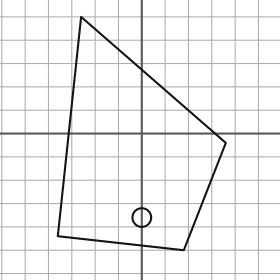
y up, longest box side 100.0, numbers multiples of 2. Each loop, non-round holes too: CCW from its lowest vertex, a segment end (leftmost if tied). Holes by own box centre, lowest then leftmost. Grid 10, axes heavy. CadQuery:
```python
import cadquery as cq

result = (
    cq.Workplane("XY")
    .moveTo(18.0, -50.0)
    .lineTo(36.0, -4.0)
    .lineTo(-26.0, 50.0)
    .lineTo(-36.0, -44.0)
    .close()
    .moveTo(0.0, -36.0)
    .circle(4.0)
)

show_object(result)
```